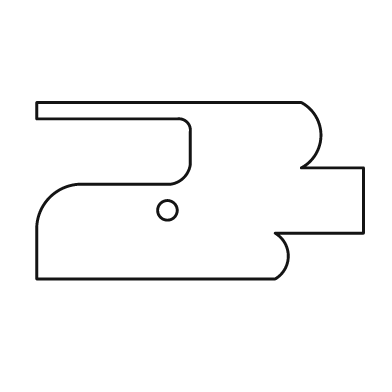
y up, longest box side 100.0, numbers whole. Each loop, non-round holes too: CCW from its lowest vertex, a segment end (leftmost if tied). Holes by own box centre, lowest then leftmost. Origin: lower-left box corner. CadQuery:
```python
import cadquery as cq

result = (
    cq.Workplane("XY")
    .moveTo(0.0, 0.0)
    .lineTo(73.0, 0.0)
    .threePointArc((77.0, 7.0), (73.0, 14.0))
    .lineTo(100.0, 14.0)
    .lineTo(100.0, 34.0)
    .lineTo(81.0, 34.0)
    .threePointArc((87.0, 44.0), (81.0, 54.0))
    .lineTo(0.0, 54.0)
    .lineTo(0.0, 49.0)
    .lineTo(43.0, 49.0)
    .threePointArc((46.0, 48.0), (47.0, 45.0))
    .lineTo(47.0, 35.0)
    .threePointArc((45.0, 31.0), (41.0, 29.0))
    .lineTo(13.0, 29.0)
    .threePointArc((4.0, 25.0), (0.0, 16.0))
    .close()
    .moveTo(40.0, 21.0)
    .circle(3.0)
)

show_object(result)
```